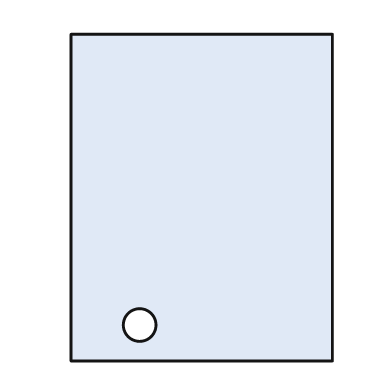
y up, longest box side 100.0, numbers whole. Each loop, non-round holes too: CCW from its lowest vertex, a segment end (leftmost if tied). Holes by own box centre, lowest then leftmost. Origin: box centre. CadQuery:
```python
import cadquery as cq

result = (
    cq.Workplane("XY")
    .moveTo(-40.0, -50.0)
    .lineTo(40.0, -50.0)
    .lineTo(40.0, 50.0)
    .lineTo(-40.0, 50.0)
    .close()
    .moveTo(-19.0, -39.0)
    .circle(5.0)
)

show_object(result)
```